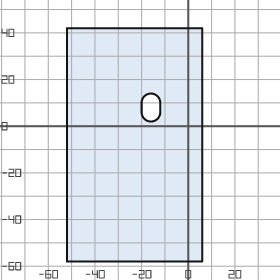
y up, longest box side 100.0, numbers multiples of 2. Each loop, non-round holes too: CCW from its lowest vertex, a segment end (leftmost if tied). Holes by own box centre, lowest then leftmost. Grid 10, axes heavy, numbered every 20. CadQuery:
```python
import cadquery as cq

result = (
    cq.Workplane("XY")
    .moveTo(-52.0, -58.0)
    .lineTo(6.0, -58.0)
    .lineTo(6.0, 42.0)
    .lineTo(-52.0, 42.0)
    .close()
    .moveTo(-20.0, 6.0)
    .threePointArc((-16.0, 2.0), (-12.0, 6.0))
    .lineTo(-12.0, 10.0)
    .threePointArc((-16.0, 14.0), (-20.0, 10.0))
    .close()
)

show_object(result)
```